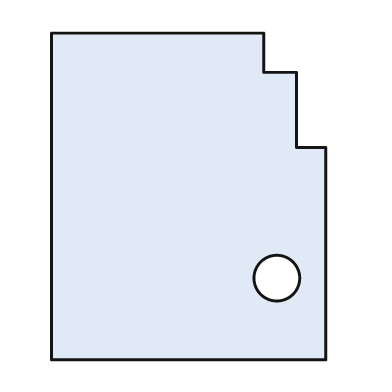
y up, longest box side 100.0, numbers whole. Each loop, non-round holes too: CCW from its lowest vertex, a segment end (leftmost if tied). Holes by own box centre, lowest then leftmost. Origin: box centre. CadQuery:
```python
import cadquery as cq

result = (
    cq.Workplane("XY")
    .moveTo(-42.0, -50.0)
    .lineTo(42.0, -50.0)
    .lineTo(42.0, 15.0)
    .lineTo(33.0, 15.0)
    .lineTo(33.0, 38.0)
    .lineTo(23.0, 38.0)
    .lineTo(23.0, 50.0)
    .lineTo(-42.0, 50.0)
    .close()
    .moveTo(27.0, -25.0)
    .circle(7.0)
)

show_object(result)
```